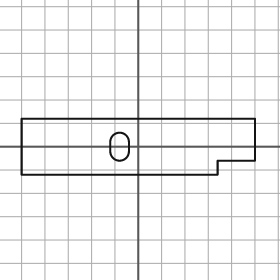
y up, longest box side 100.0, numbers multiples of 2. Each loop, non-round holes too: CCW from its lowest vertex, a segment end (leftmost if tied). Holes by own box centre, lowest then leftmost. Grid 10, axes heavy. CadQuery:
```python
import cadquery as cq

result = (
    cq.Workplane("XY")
    .moveTo(-50.0, -12.0)
    .lineTo(34.0, -12.0)
    .lineTo(34.0, -6.0)
    .lineTo(50.0, -6.0)
    .lineTo(50.0, 12.0)
    .lineTo(-50.0, 12.0)
    .close()
    .moveTo(-12.0, -2.0)
    .threePointArc((-8.0, -6.0), (-4.0, -2.0))
    .lineTo(-4.0, 2.0)
    .threePointArc((-8.0, 6.0), (-12.0, 2.0))
    .close()
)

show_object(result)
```